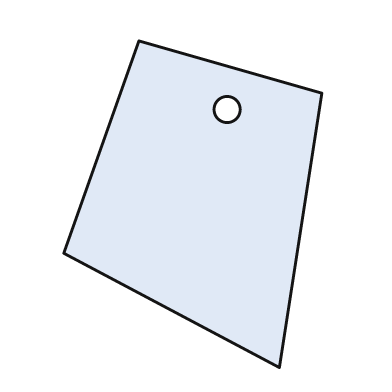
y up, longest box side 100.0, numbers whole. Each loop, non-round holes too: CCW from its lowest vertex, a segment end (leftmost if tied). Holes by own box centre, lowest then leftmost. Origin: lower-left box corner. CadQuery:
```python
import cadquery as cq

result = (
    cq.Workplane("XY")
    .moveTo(66.0, 0.0)
    .lineTo(79.0, 84.0)
    .lineTo(23.0, 100.0)
    .lineTo(0.0, 35.0)
    .close()
    .moveTo(50.0, 79.0)
    .circle(4.0)
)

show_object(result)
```